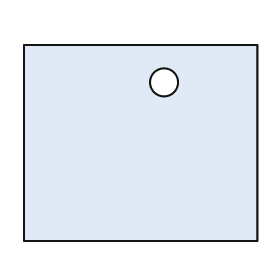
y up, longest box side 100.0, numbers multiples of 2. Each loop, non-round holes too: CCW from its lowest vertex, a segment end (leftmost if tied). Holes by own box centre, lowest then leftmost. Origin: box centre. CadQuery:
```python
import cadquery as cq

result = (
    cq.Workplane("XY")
    .moveTo(-50.0, -42.0)
    .lineTo(50.0, -42.0)
    .lineTo(50.0, 42.0)
    .lineTo(-50.0, 42.0)
    .close()
    .moveTo(10.0, 26.0)
    .circle(6.0)
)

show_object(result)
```